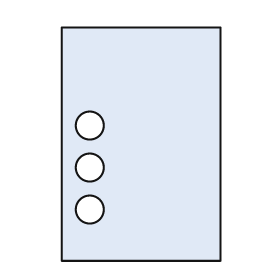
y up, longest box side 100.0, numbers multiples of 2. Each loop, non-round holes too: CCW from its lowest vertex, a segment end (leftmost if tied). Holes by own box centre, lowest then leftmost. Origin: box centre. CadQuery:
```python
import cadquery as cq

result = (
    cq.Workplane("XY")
    .moveTo(-34.0, -50.0)
    .lineTo(34.0, -50.0)
    .lineTo(34.0, 50.0)
    .lineTo(-34.0, 50.0)
    .close()
    .moveTo(-22.0, -28.0)
    .circle(6.0)
    .moveTo(-22.0, -10.0)
    .circle(6.0)
    .moveTo(-22.0, 8.0)
    .circle(6.0)
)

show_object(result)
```